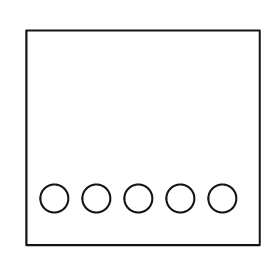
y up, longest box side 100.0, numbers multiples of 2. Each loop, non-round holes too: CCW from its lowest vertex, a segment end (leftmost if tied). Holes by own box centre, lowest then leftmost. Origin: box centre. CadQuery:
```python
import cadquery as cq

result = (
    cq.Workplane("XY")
    .moveTo(-50.0, -46.0)
    .lineTo(50.0, -46.0)
    .lineTo(50.0, 46.0)
    .lineTo(-50.0, 46.0)
    .close()
    .moveTo(-38.0, -26.0)
    .circle(6.0)
    .moveTo(-20.0, -26.0)
    .circle(6.0)
    .moveTo(-2.0, -26.0)
    .circle(6.0)
    .moveTo(16.0, -26.0)
    .circle(6.0)
    .moveTo(34.0, -26.0)
    .circle(6.0)
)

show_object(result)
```